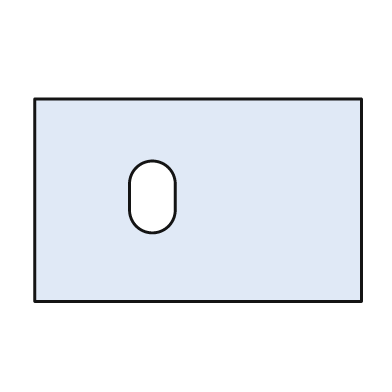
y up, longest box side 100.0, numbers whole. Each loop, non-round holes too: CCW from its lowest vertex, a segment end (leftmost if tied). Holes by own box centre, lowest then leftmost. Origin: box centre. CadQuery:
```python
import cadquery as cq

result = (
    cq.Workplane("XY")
    .moveTo(-50.0, -31.0)
    .lineTo(50.0, -31.0)
    .lineTo(50.0, 31.0)
    .lineTo(-50.0, 31.0)
    .close()
    .moveTo(-21.0, -3.0)
    .threePointArc((-14.0, -10.0), (-7.0, -3.0))
    .lineTo(-7.0, 5.0)
    .threePointArc((-14.0, 12.0), (-21.0, 5.0))
    .close()
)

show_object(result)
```